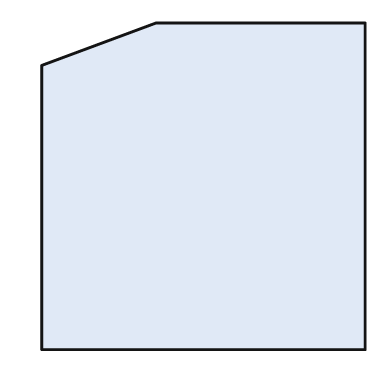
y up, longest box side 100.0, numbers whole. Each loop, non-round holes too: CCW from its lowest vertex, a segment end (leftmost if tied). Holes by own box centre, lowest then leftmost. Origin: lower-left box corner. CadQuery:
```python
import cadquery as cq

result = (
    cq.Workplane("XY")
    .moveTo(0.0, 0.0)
    .lineTo(99.0, 0.0)
    .lineTo(99.0, 100.0)
    .lineTo(35.0, 100.0)
    .lineTo(0.0, 87.0)
    .close()
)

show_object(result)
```